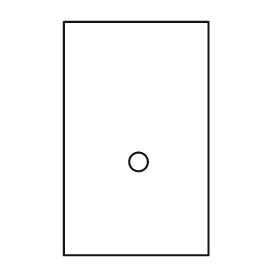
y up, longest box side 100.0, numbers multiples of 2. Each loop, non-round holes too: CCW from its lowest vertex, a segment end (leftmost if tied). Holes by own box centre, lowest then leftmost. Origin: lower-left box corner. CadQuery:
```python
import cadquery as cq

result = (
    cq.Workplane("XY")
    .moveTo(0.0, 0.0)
    .lineTo(62.0, 0.0)
    .lineTo(62.0, 100.0)
    .lineTo(0.0, 100.0)
    .close()
    .moveTo(32.0, 40.0)
    .circle(4.0)
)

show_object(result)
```